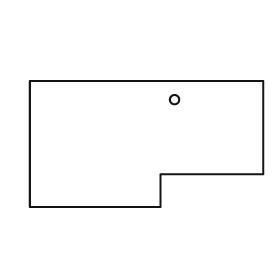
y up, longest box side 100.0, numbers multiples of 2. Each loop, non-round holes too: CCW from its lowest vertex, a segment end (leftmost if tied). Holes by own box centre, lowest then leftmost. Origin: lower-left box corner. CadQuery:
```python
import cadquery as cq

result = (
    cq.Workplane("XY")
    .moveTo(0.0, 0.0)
    .lineTo(56.0, 0.0)
    .lineTo(56.0, 14.0)
    .lineTo(100.0, 14.0)
    .lineTo(100.0, 54.0)
    .lineTo(0.0, 54.0)
    .close()
    .moveTo(62.0, 46.0)
    .circle(2.0)
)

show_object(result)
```